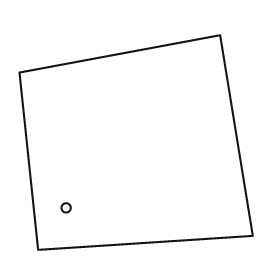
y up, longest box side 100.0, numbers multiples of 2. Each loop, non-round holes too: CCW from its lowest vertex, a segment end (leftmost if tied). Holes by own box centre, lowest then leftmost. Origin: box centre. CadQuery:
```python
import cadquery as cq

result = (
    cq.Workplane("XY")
    .moveTo(-42.0, -46.0)
    .lineTo(50.0, -40.0)
    .lineTo(36.0, 46.0)
    .lineTo(-50.0, 30.0)
    .close()
    .moveTo(-30.0, -28.0)
    .circle(2.0)
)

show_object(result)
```